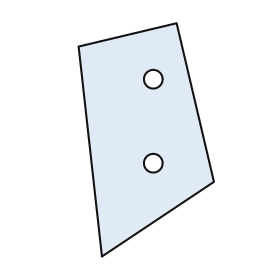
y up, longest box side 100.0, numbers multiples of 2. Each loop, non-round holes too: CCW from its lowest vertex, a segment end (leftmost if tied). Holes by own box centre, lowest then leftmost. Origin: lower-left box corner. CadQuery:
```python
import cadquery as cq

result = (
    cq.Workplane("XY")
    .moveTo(10.0, 0.0)
    .lineTo(58.0, 32.0)
    .lineTo(42.0, 100.0)
    .lineTo(0.0, 90.0)
    .close()
    .moveTo(32.0, 40.0)
    .circle(4.0)
    .moveTo(32.0, 76.0)
    .circle(4.0)
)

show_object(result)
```